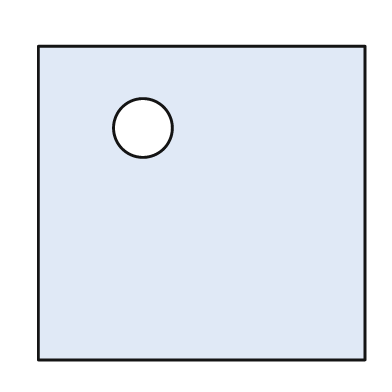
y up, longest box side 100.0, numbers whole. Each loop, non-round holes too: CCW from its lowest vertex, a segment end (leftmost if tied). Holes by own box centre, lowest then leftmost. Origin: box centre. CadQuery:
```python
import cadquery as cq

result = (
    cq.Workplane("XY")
    .moveTo(-50.0, -48.0)
    .lineTo(50.0, -48.0)
    .lineTo(50.0, 48.0)
    .lineTo(-50.0, 48.0)
    .close()
    .moveTo(-18.0, 23.0)
    .circle(9.0)
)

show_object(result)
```